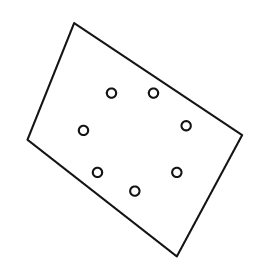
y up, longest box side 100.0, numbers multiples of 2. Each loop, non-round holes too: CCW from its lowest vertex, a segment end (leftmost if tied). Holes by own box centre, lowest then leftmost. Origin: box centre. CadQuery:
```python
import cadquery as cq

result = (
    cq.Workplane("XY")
    .moveTo(18.0, -50.0)
    .lineTo(46.0, 2.0)
    .lineTo(-26.0, 50.0)
    .lineTo(-46.0, 0.0)
    .close()
    .moveTo(0.0, -22.0)
    .circle(2.0)
    .moveTo(-16.0, -14.0)
    .circle(2.0)
    .moveTo(18.0, -14.0)
    .circle(2.0)
    .moveTo(-22.0, 4.0)
    .circle(2.0)
    .moveTo(22.0, 6.0)
    .circle(2.0)
    .moveTo(-10.0, 20.0)
    .circle(2.0)
    .moveTo(8.0, 20.0)
    .circle(2.0)
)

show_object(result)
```